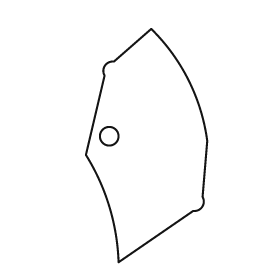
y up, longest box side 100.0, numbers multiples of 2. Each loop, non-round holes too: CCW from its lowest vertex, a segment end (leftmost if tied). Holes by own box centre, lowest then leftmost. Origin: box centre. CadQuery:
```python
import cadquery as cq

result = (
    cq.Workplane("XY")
    .moveTo(-12.0, -50.0)
    .lineTo(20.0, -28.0)
    .threePointArc((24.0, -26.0), (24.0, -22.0))
    .lineTo(26.0, 2.0)
    .threePointArc((18.0, 28.0), (2.0, 50.0))
    .lineTo(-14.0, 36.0)
    .threePointArc((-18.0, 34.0), (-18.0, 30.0))
    .lineTo(-26.0, -4.0)
    .threePointArc((-16.0, -26.0), (-12.0, -50.0))
    .close()
    .moveTo(-16.0, 4.0)
    .circle(4.0)
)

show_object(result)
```